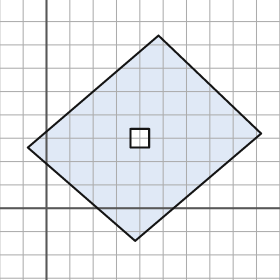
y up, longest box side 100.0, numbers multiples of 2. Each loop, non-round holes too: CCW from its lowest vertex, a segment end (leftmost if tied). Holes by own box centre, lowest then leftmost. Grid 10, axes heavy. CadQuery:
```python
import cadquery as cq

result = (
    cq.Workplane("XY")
    .moveTo(38.0, -14.0)
    .lineTo(92.0, 32.0)
    .lineTo(48.0, 74.0)
    .lineTo(-8.0, 26.0)
    .close()
    .moveTo(36.0, 26.0)
    .lineTo(44.0, 26.0)
    .lineTo(44.0, 34.0)
    .lineTo(36.0, 34.0)
    .close()
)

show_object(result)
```